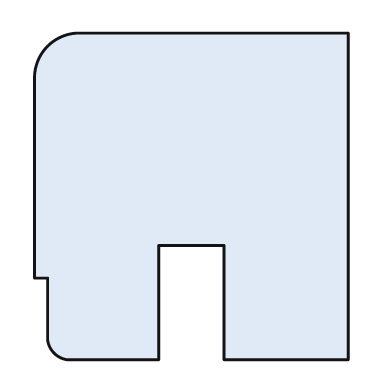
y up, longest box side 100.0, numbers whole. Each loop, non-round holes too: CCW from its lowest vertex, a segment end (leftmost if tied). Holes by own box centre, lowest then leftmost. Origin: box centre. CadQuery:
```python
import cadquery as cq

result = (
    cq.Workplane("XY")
    .moveTo(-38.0, -50.0)
    .lineTo(-10.0, -50.0)
    .lineTo(-10.0, -15.0)
    .lineTo(10.0, -15.0)
    .lineTo(10.0, -50.0)
    .lineTo(48.0, -50.0)
    .lineTo(48.0, 50.0)
    .lineTo(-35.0, 50.0)
    .threePointArc((-44.0, 46.0), (-48.0, 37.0))
    .lineTo(-48.0, -25.0)
    .lineTo(-44.0, -25.0)
    .lineTo(-44.0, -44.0)
    .threePointArc((-42.0, -48.0), (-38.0, -50.0))
    .close()
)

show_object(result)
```